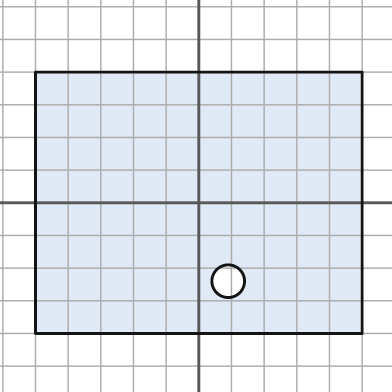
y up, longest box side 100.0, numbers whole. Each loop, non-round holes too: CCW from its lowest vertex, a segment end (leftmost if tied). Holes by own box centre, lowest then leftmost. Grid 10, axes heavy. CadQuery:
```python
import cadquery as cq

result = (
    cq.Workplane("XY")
    .moveTo(-50.0, -40.0)
    .lineTo(50.0, -40.0)
    .lineTo(50.0, 40.0)
    .lineTo(-50.0, 40.0)
    .close()
    .moveTo(9.0, -24.0)
    .circle(5.0)
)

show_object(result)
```